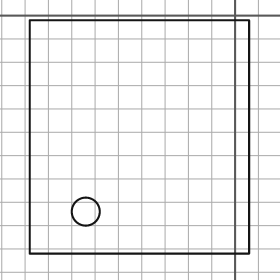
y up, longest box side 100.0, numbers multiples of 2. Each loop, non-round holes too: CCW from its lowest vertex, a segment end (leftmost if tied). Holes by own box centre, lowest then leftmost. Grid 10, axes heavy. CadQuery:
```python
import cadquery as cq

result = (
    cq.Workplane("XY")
    .moveTo(-88.0, -102.0)
    .lineTo(6.0, -102.0)
    .lineTo(6.0, -2.0)
    .lineTo(-88.0, -2.0)
    .close()
    .moveTo(-64.0, -84.0)
    .circle(6.0)
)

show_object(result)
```